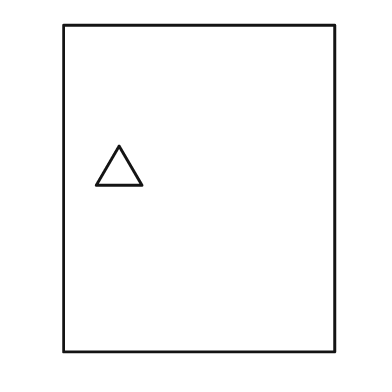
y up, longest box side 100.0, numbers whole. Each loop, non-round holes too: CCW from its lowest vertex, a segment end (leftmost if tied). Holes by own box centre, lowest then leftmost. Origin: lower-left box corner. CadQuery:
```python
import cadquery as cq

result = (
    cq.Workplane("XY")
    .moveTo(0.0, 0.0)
    .lineTo(83.0, 0.0)
    .lineTo(83.0, 100.0)
    .lineTo(0.0, 100.0)
    .close()
    .moveTo(10.0, 51.0)
    .lineTo(24.0, 51.0)
    .lineTo(17.0, 63.0)
    .close()
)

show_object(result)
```